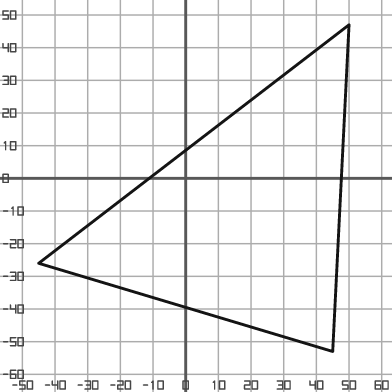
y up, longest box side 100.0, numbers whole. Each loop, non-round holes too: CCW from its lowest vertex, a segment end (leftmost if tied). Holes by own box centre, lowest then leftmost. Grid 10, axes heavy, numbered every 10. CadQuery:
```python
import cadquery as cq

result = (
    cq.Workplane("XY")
    .moveTo(45.0, -53.0)
    .lineTo(50.0, 47.0)
    .lineTo(-45.0, -26.0)
    .close()
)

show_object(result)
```